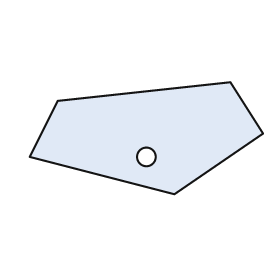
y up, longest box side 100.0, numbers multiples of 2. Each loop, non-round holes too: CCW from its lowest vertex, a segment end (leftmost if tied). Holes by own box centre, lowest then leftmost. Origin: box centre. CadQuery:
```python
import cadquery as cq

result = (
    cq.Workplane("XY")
    .moveTo(12.0, -24.0)
    .lineTo(50.0, 2.0)
    .lineTo(36.0, 24.0)
    .lineTo(-38.0, 16.0)
    .lineTo(-50.0, -8.0)
    .close()
    .moveTo(0.0, -8.0)
    .circle(4.0)
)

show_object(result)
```